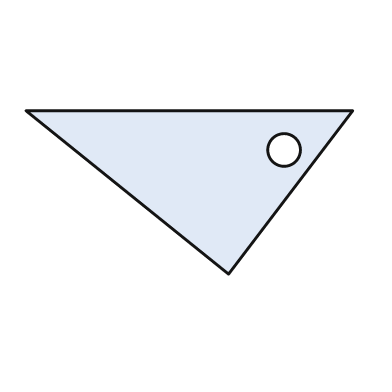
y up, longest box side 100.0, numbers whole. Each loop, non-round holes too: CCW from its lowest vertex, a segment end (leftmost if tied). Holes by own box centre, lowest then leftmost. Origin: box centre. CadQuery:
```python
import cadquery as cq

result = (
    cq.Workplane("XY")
    .moveTo(12.0, -25.0)
    .lineTo(50.0, 25.0)
    .lineTo(-50.0, 25.0)
    .close()
    .moveTo(29.0, 13.0)
    .circle(5.0)
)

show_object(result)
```